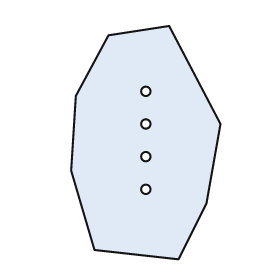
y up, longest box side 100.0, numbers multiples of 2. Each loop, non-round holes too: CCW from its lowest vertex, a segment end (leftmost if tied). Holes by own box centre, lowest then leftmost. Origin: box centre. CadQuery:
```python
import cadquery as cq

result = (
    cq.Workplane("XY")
    .moveTo(14.0, -50.0)
    .lineTo(26.0, -26.0)
    .lineTo(32.0, 8.0)
    .lineTo(10.0, 50.0)
    .lineTo(-16.0, 46.0)
    .lineTo(-30.0, 20.0)
    .lineTo(-32.0, -12.0)
    .lineTo(-22.0, -46.0)
    .close()
    .moveTo(0.0, -20.0)
    .circle(2.0)
    .moveTo(0.0, -6.0)
    .circle(2.0)
    .moveTo(0.0, 8.0)
    .circle(2.0)
    .moveTo(0.0, 22.0)
    .circle(2.0)
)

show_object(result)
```